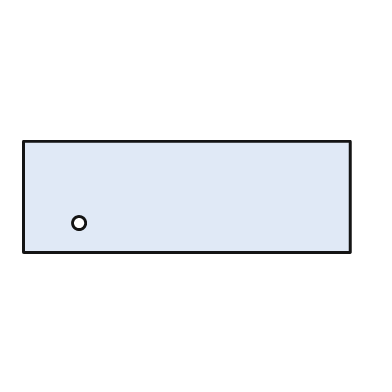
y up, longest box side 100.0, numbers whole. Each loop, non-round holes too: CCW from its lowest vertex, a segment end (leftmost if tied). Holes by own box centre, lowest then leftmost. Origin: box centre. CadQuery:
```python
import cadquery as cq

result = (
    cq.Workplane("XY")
    .moveTo(-50.0, -17.0)
    .lineTo(50.0, -17.0)
    .lineTo(50.0, 17.0)
    .lineTo(-50.0, 17.0)
    .close()
    .moveTo(-33.0, -8.0)
    .circle(2.0)
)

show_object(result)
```